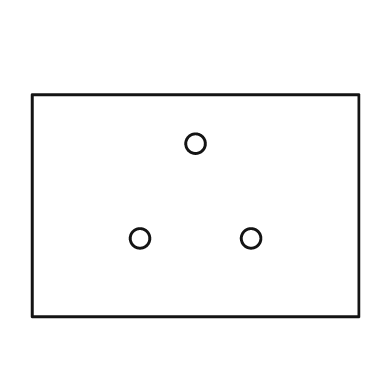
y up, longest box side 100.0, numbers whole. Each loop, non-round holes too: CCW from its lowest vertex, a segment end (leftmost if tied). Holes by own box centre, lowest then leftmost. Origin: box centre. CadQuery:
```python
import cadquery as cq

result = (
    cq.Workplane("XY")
    .moveTo(-50.0, -34.0)
    .lineTo(50.0, -34.0)
    .lineTo(50.0, 34.0)
    .lineTo(-50.0, 34.0)
    .close()
    .moveTo(-17.0, -10.0)
    .circle(3.0)
    .moveTo(17.0, -10.0)
    .circle(3.0)
    .moveTo(0.0, 19.0)
    .circle(3.0)
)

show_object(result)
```